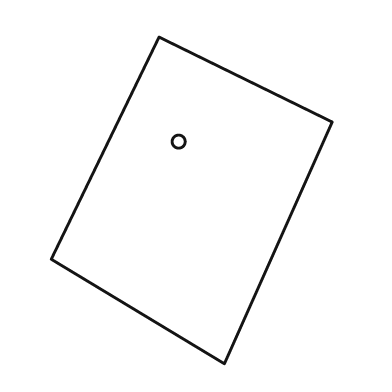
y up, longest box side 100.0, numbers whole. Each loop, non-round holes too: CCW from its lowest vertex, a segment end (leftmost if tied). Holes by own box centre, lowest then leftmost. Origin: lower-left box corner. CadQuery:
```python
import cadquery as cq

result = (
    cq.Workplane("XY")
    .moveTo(53.0, 0.0)
    .lineTo(86.0, 74.0)
    .lineTo(33.0, 100.0)
    .lineTo(0.0, 32.0)
    .close()
    .moveTo(39.0, 68.0)
    .circle(2.0)
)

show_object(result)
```